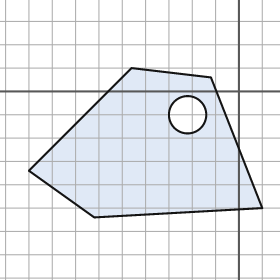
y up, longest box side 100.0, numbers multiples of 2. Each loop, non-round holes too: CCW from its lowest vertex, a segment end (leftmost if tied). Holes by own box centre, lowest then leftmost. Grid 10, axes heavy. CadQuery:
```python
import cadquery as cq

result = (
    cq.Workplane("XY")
    .moveTo(-62.0, -54.0)
    .lineTo(10.0, -50.0)
    .lineTo(-12.0, 6.0)
    .lineTo(-46.0, 10.0)
    .lineTo(-90.0, -34.0)
    .close()
    .moveTo(-22.0, -10.0)
    .circle(8.0)
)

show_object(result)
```